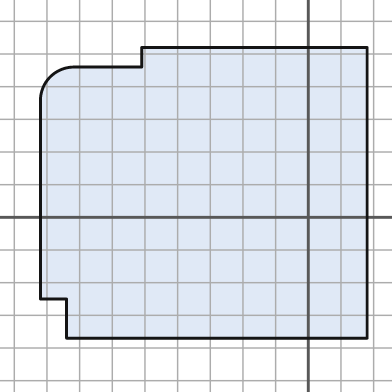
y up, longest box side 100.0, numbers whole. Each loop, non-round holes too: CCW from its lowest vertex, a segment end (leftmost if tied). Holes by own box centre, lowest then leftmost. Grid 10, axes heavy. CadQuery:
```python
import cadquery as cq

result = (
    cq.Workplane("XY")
    .moveTo(-74.0, -37.0)
    .lineTo(18.0, -37.0)
    .lineTo(18.0, 52.0)
    .lineTo(-51.0, 52.0)
    .lineTo(-51.0, 46.0)
    .lineTo(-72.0, 46.0)
    .threePointArc((-79.0, 43.0), (-82.0, 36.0))
    .lineTo(-82.0, -25.0)
    .lineTo(-74.0, -25.0)
    .close()
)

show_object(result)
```